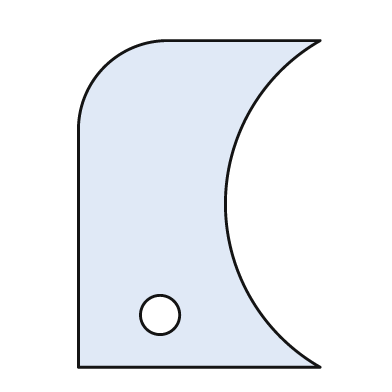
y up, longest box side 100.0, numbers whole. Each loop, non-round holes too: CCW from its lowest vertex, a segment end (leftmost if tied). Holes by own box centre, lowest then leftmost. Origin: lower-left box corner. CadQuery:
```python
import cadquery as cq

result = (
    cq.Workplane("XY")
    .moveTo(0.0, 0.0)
    .lineTo(74.0, 0.0)
    .threePointArc((45.0, 50.0), (74.0, 100.0))
    .lineTo(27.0, 100.0)
    .threePointArc((8.0, 92.0), (0.0, 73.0))
    .close()
    .moveTo(25.0, 16.0)
    .circle(6.0)
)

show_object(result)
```